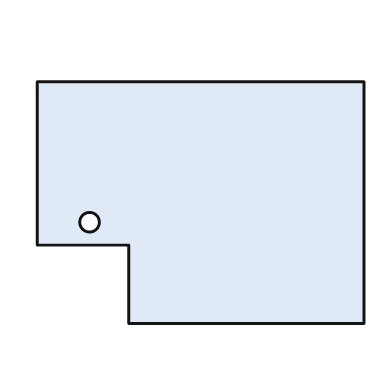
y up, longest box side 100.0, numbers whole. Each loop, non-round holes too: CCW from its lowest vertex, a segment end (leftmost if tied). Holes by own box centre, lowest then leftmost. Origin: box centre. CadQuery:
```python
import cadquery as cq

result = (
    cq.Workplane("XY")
    .moveTo(-22.0, -37.0)
    .lineTo(50.0, -37.0)
    .lineTo(50.0, 37.0)
    .lineTo(-50.0, 37.0)
    .lineTo(-50.0, -13.0)
    .lineTo(-22.0, -13.0)
    .close()
    .moveTo(-34.0, -6.0)
    .circle(3.0)
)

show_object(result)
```